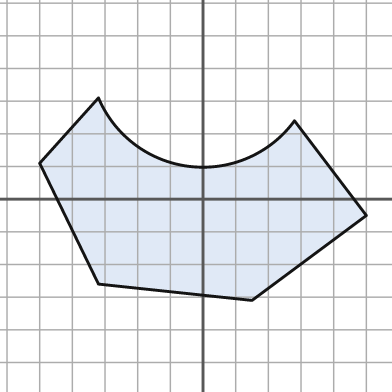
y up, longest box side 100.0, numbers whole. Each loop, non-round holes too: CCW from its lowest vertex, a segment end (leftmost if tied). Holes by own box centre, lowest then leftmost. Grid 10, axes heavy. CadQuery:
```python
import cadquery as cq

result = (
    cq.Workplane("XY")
    .moveTo(15.0, -31.0)
    .lineTo(50.0, -5.0)
    .lineTo(28.0, 24.0)
    .threePointArc((-4.0, 10.0), (-32.0, 31.0))
    .lineTo(-50.0, 11.0)
    .lineTo(-32.0, -26.0)
    .close()
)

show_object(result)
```